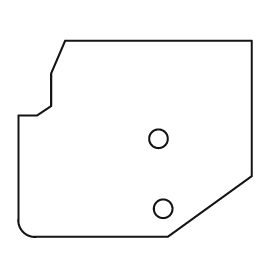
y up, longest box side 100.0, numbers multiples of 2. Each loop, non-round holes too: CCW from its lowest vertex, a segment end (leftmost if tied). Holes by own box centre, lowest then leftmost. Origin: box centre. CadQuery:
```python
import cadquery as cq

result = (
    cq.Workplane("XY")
    .moveTo(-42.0, -42.0)
    .lineTo(14.0, -42.0)
    .lineTo(50.0, -16.0)
    .lineTo(50.0, 42.0)
    .lineTo(-30.0, 42.0)
    .lineTo(-36.0, 28.0)
    .lineTo(-36.0, 14.0)
    .lineTo(-42.0, 10.0)
    .lineTo(-50.0, 10.0)
    .lineTo(-50.0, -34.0)
    .threePointArc((-48.0, -40.0), (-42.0, -42.0))
    .close()
    .moveTo(12.0, -30.0)
    .circle(4.0)
    .moveTo(10.0, 0.0)
    .circle(4.0)
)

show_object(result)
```